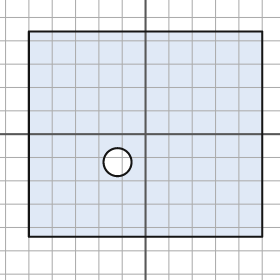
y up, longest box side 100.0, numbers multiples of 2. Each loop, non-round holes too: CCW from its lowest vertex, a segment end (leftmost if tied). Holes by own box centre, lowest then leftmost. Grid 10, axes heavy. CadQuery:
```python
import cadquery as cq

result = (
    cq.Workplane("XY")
    .moveTo(-50.0, -44.0)
    .lineTo(50.0, -44.0)
    .lineTo(50.0, 44.0)
    .lineTo(-50.0, 44.0)
    .close()
    .moveTo(-12.0, -12.0)
    .circle(6.0)
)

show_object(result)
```